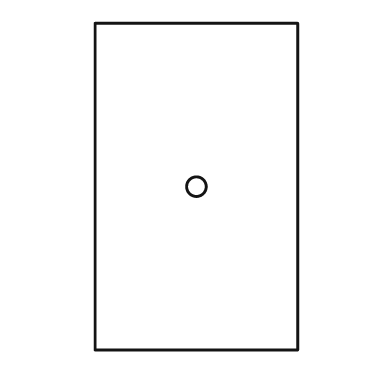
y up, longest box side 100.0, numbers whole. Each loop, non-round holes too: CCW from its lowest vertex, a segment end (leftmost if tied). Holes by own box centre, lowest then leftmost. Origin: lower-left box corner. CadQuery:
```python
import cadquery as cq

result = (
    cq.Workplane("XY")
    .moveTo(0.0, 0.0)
    .lineTo(62.0, 0.0)
    .lineTo(62.0, 100.0)
    .lineTo(0.0, 100.0)
    .close()
    .moveTo(31.0, 50.0)
    .circle(3.0)
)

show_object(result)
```